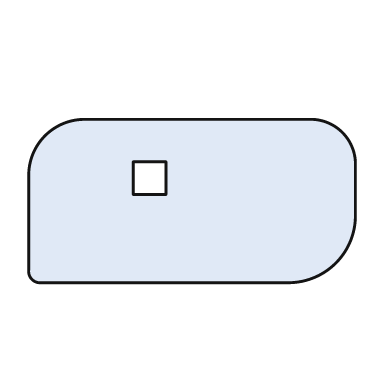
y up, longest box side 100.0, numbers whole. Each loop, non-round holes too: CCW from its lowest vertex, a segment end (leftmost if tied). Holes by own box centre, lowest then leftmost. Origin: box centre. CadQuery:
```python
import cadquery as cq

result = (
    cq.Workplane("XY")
    .moveTo(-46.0, -25.0)
    .lineTo(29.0, -25.0)
    .threePointArc((44.0, -19.0), (50.0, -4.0))
    .lineTo(50.0, 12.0)
    .threePointArc((46.0, 21.0), (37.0, 25.0))
    .lineTo(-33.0, 25.0)
    .threePointArc((-45.0, 20.0), (-50.0, 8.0))
    .lineTo(-50.0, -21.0)
    .threePointArc((-49.0, -24.0), (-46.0, -25.0))
    .close()
    .moveTo(-18.0, 2.0)
    .lineTo(-8.0, 2.0)
    .lineTo(-8.0, 12.0)
    .lineTo(-18.0, 12.0)
    .close()
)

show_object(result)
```